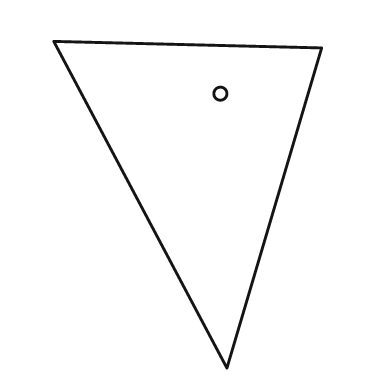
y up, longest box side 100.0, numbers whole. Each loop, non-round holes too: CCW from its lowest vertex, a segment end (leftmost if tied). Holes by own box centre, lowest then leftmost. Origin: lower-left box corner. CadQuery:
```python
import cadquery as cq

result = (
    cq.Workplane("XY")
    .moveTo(53.0, 0.0)
    .lineTo(82.0, 98.0)
    .lineTo(0.0, 100.0)
    .close()
    .moveTo(51.0, 84.0)
    .circle(2.0)
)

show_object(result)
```